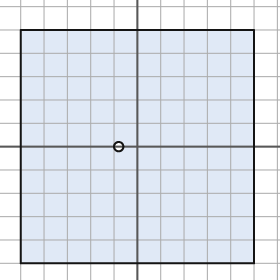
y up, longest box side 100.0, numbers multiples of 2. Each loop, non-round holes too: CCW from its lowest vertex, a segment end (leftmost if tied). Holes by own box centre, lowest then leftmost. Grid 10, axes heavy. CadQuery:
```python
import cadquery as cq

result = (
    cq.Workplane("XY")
    .moveTo(-50.0, -50.0)
    .lineTo(50.0, -50.0)
    .lineTo(50.0, 50.0)
    .lineTo(-50.0, 50.0)
    .close()
    .moveTo(-8.0, 0.0)
    .circle(2.0)
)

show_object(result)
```